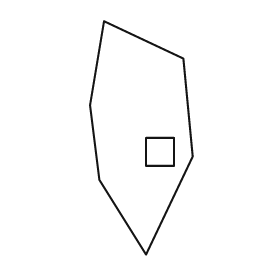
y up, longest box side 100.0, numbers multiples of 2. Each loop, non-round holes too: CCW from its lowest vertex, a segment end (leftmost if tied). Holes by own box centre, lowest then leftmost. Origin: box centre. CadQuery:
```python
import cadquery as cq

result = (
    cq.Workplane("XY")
    .moveTo(2.0, -50.0)
    .lineTo(22.0, -8.0)
    .lineTo(18.0, 34.0)
    .lineTo(-16.0, 50.0)
    .lineTo(-22.0, 14.0)
    .lineTo(-18.0, -18.0)
    .close()
    .moveTo(2.0, -12.0)
    .lineTo(14.0, -12.0)
    .lineTo(14.0, 0.0)
    .lineTo(2.0, 0.0)
    .close()
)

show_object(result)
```